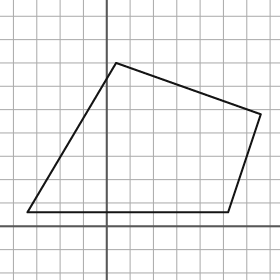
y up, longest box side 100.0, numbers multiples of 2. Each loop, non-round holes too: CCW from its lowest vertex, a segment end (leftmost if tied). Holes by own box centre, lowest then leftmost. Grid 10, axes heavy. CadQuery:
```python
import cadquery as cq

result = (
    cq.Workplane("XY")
    .moveTo(-34.0, 6.0)
    .lineTo(52.0, 6.0)
    .lineTo(66.0, 48.0)
    .lineTo(4.0, 70.0)
    .close()
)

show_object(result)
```